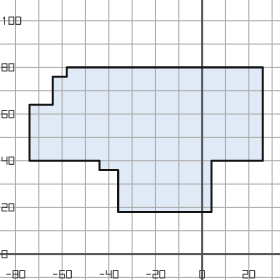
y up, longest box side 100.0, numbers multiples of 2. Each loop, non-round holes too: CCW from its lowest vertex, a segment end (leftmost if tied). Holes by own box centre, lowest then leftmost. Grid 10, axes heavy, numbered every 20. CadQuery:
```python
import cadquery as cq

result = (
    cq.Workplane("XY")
    .moveTo(-36.0, 18.0)
    .lineTo(4.0, 18.0)
    .lineTo(4.0, 40.0)
    .lineTo(26.0, 40.0)
    .lineTo(26.0, 80.0)
    .lineTo(-58.0, 80.0)
    .lineTo(-58.0, 76.0)
    .lineTo(-64.0, 76.0)
    .lineTo(-64.0, 64.0)
    .lineTo(-74.0, 64.0)
    .lineTo(-74.0, 40.0)
    .lineTo(-44.0, 40.0)
    .lineTo(-44.0, 36.0)
    .lineTo(-36.0, 36.0)
    .close()
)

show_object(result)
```